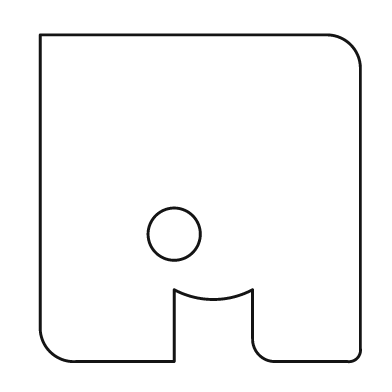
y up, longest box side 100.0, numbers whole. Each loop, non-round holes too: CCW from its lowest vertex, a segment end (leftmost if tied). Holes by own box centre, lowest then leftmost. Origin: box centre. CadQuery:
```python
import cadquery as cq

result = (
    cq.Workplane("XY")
    .moveTo(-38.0, -50.0)
    .lineTo(-8.0, -50.0)
    .lineTo(-8.0, -28.0)
    .threePointArc((4.0, -31.0), (16.0, -28.0))
    .lineTo(16.0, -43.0)
    .threePointArc((18.0, -48.0), (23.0, -50.0))
    .lineTo(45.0, -50.0)
    .threePointArc((48.0, -49.0), (49.0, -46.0))
    .lineTo(49.0, 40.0)
    .threePointArc((46.0, 47.0), (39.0, 50.0))
    .lineTo(-49.0, 50.0)
    .lineTo(-49.0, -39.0)
    .threePointArc((-46.0, -47.0), (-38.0, -50.0))
    .close()
    .moveTo(-8.0, -11.0)
    .circle(8.0)
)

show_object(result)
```